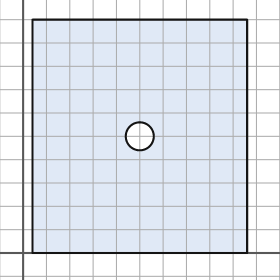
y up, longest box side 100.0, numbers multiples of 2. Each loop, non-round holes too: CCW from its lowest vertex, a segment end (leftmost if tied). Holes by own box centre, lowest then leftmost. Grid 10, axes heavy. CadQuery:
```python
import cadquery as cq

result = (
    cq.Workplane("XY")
    .moveTo(4.0, 0.0)
    .lineTo(96.0, 0.0)
    .lineTo(96.0, 100.0)
    .lineTo(4.0, 100.0)
    .close()
    .moveTo(50.0, 50.0)
    .circle(6.0)
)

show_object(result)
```